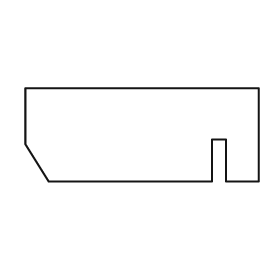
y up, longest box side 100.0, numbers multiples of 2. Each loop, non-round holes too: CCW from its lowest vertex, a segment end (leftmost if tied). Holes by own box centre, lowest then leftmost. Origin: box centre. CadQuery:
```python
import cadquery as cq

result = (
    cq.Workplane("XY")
    .moveTo(-40.0, -20.0)
    .lineTo(30.0, -20.0)
    .lineTo(30.0, -2.0)
    .lineTo(36.0, -2.0)
    .lineTo(36.0, -20.0)
    .lineTo(50.0, -20.0)
    .lineTo(50.0, 20.0)
    .lineTo(-50.0, 20.0)
    .lineTo(-50.0, -4.0)
    .close()
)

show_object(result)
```